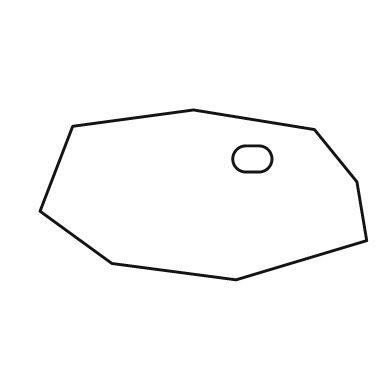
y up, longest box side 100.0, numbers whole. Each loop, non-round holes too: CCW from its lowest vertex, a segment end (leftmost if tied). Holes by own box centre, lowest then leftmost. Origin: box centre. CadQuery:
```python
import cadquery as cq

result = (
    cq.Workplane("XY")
    .moveTo(10.0, -26.0)
    .lineTo(50.0, -14.0)
    .lineTo(47.0, 4.0)
    .lineTo(34.0, 20.0)
    .lineTo(-3.0, 26.0)
    .lineTo(-40.0, 21.0)
    .lineTo(-50.0, -5.0)
    .lineTo(-28.0, -21.0)
    .close()
    .moveTo(13.0, 7.0)
    .lineTo(17.0, 7.0)
    .threePointArc((21.0, 11.0), (17.0, 15.0))
    .lineTo(13.0, 15.0)
    .threePointArc((9.0, 11.0), (13.0, 7.0))
    .close()
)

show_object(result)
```